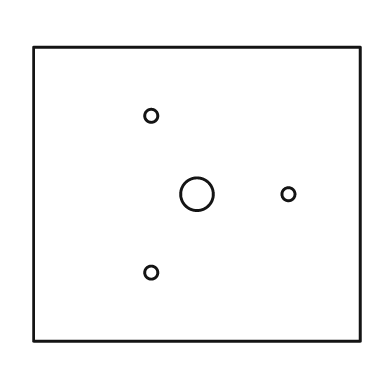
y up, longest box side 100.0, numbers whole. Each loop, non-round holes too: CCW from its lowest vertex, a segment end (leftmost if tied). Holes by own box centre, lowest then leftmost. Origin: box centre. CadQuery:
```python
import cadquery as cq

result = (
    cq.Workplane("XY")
    .moveTo(-50.0, -45.0)
    .lineTo(50.0, -45.0)
    .lineTo(50.0, 45.0)
    .lineTo(-50.0, 45.0)
    .close()
    .moveTo(-14.0, -24.0)
    .circle(2.0)
    .moveTo(0.0, 0.0)
    .circle(5.0)
    .moveTo(28.0, 0.0)
    .circle(2.0)
    .moveTo(-14.0, 24.0)
    .circle(2.0)
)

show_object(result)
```